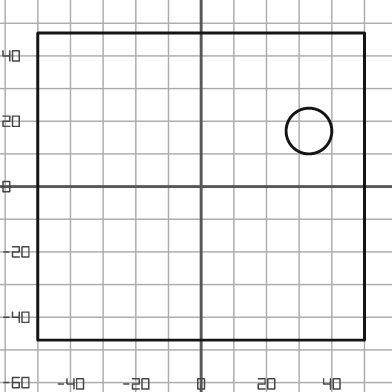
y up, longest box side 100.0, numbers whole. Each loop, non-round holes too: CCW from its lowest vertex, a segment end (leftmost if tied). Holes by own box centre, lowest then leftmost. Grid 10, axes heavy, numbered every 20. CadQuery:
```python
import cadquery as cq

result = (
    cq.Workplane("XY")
    .moveTo(-50.0, -47.0)
    .lineTo(50.0, -47.0)
    .lineTo(50.0, 47.0)
    .lineTo(-50.0, 47.0)
    .close()
    .moveTo(33.0, 17.0)
    .circle(7.0)
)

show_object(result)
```